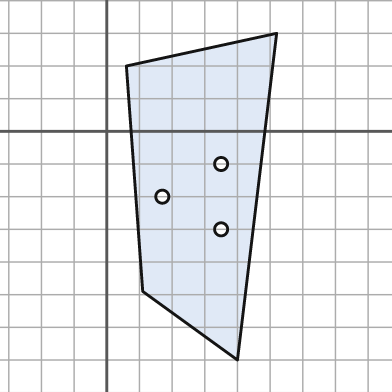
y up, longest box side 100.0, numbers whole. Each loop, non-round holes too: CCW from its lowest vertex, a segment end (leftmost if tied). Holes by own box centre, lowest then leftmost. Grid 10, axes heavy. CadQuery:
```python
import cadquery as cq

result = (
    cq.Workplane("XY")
    .moveTo(40.0, -70.0)
    .lineTo(52.0, 30.0)
    .lineTo(6.0, 20.0)
    .lineTo(11.0, -49.0)
    .close()
    .moveTo(35.0, -30.0)
    .circle(2.0)
    .moveTo(17.0, -20.0)
    .circle(2.0)
    .moveTo(35.0, -10.0)
    .circle(2.0)
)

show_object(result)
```